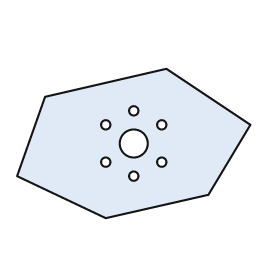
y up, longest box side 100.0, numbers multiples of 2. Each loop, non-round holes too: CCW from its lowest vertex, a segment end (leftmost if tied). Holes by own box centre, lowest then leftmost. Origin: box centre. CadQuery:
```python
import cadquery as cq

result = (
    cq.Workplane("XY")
    .moveTo(-12.0, -32.0)
    .lineTo(32.0, -22.0)
    .lineTo(50.0, 8.0)
    .lineTo(14.0, 32.0)
    .lineTo(-38.0, 20.0)
    .lineTo(-50.0, -14.0)
    .close()
    .moveTo(0.0, -14.0)
    .circle(2.0)
    .moveTo(-12.0, -8.0)
    .circle(2.0)
    .moveTo(12.0, -8.0)
    .circle(2.0)
    .moveTo(0.0, 0.0)
    .circle(6.0)
    .moveTo(-12.0, 8.0)
    .circle(2.0)
    .moveTo(12.0, 8.0)
    .circle(2.0)
    .moveTo(0.0, 14.0)
    .circle(2.0)
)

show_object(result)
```